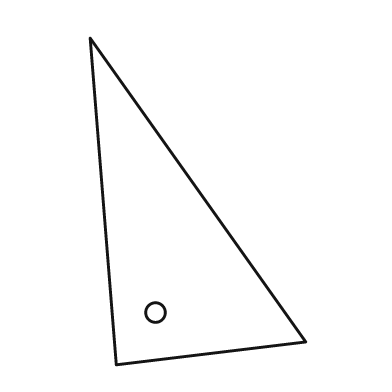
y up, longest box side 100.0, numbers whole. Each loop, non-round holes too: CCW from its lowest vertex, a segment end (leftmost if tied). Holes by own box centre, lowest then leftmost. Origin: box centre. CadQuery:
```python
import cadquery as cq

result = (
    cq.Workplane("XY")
    .moveTo(-25.0, -50.0)
    .lineTo(33.0, -43.0)
    .lineTo(-33.0, 50.0)
    .close()
    .moveTo(-13.0, -34.0)
    .circle(3.0)
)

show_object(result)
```